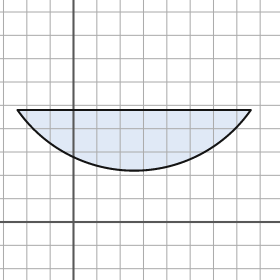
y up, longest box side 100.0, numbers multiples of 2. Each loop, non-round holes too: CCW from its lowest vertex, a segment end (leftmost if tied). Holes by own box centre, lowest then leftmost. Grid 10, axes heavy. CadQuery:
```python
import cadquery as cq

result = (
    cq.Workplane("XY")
    .moveTo(-24.0, 48.0)
    .threePointArc((26.0, 22.0), (76.0, 48.0))
    .close()
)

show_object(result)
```